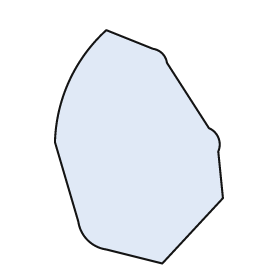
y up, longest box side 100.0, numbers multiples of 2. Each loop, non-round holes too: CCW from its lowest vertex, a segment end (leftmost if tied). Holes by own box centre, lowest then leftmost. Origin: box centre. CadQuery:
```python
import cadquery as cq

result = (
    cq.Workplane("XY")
    .moveTo(10.0, -50.0)
    .lineTo(36.0, -22.0)
    .lineTo(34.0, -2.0)
    .threePointArc((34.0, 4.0), (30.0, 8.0))
    .lineTo(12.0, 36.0)
    .threePointArc((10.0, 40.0), (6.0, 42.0))
    .lineTo(-14.0, 50.0)
    .threePointArc((-30.0, 28.0), (-36.0, 2.0))
    .lineTo(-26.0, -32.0)
    .threePointArc((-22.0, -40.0), (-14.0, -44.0))
    .close()
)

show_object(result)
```